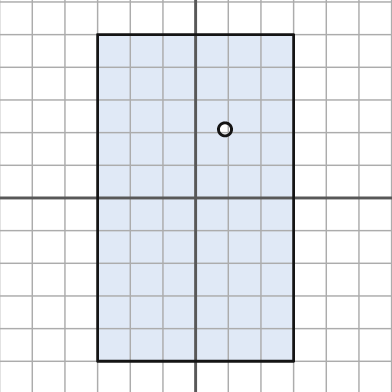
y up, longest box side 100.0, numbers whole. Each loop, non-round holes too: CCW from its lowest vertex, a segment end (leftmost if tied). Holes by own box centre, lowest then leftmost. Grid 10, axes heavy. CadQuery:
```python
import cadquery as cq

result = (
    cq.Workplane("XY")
    .moveTo(-30.0, -50.0)
    .lineTo(30.0, -50.0)
    .lineTo(30.0, 50.0)
    .lineTo(-30.0, 50.0)
    .close()
    .moveTo(9.0, 21.0)
    .circle(2.0)
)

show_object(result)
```